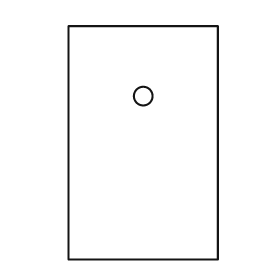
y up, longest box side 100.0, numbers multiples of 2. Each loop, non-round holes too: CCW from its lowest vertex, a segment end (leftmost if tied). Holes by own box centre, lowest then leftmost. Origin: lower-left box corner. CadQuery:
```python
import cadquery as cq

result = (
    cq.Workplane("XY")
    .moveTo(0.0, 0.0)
    .lineTo(64.0, 0.0)
    .lineTo(64.0, 100.0)
    .lineTo(0.0, 100.0)
    .close()
    .moveTo(32.0, 70.0)
    .circle(4.0)
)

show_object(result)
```